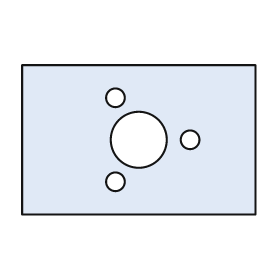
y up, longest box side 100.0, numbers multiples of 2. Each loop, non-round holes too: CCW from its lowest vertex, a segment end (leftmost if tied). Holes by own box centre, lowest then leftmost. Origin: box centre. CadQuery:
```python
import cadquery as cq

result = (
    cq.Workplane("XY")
    .moveTo(-50.0, -32.0)
    .lineTo(50.0, -32.0)
    .lineTo(50.0, 32.0)
    .lineTo(-50.0, 32.0)
    .close()
    .moveTo(-10.0, -18.0)
    .circle(4.0)
    .moveTo(0.0, 0.0)
    .circle(12.0)
    .moveTo(22.0, 0.0)
    .circle(4.0)
    .moveTo(-10.0, 18.0)
    .circle(4.0)
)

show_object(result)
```